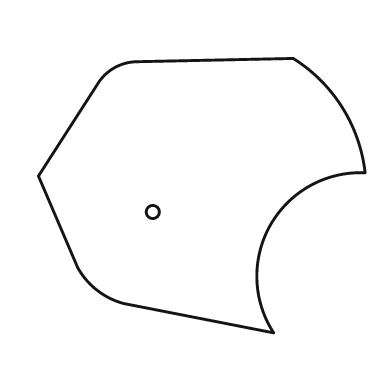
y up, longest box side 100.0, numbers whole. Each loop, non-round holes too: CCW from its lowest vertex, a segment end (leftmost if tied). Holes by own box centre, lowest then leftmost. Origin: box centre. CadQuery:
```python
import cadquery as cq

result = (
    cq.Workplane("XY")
    .moveTo(22.0, -42.0)
    .threePointArc((21.0, -9.0), (50.0, 7.0))
    .threePointArc((43.0, 27.0), (28.0, 42.0))
    .lineTo(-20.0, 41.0)
    .threePointArc((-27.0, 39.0), (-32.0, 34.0))
    .lineTo(-50.0, 6.0)
    .lineTo(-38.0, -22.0)
    .threePointArc((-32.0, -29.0), (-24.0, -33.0))
    .close()
    .moveTo(-15.0, -5.0)
    .circle(2.0)
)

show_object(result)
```